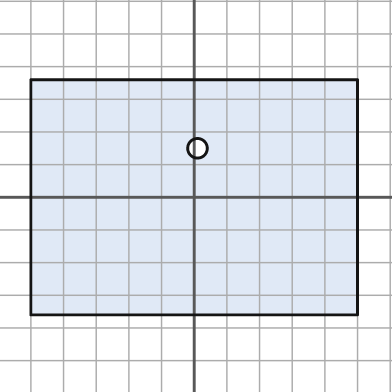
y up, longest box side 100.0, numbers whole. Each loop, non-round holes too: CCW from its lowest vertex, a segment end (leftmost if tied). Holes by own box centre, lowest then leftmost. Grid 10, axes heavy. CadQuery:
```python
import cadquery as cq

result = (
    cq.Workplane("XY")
    .moveTo(-50.0, -36.0)
    .lineTo(50.0, -36.0)
    .lineTo(50.0, 36.0)
    .lineTo(-50.0, 36.0)
    .close()
    .moveTo(1.0, 15.0)
    .circle(3.0)
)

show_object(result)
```